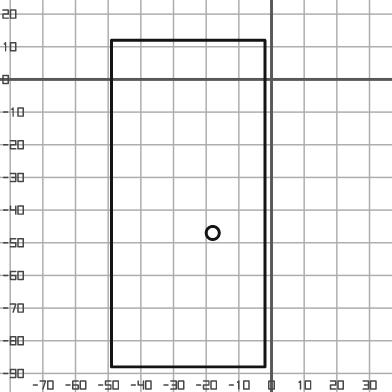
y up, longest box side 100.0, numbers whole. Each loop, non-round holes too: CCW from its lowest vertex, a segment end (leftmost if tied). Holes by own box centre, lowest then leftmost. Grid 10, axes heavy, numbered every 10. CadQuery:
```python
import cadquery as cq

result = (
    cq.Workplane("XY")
    .moveTo(-49.0, -88.0)
    .lineTo(-2.0, -88.0)
    .lineTo(-2.0, 12.0)
    .lineTo(-49.0, 12.0)
    .close()
    .moveTo(-18.0, -47.0)
    .circle(2.0)
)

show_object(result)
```